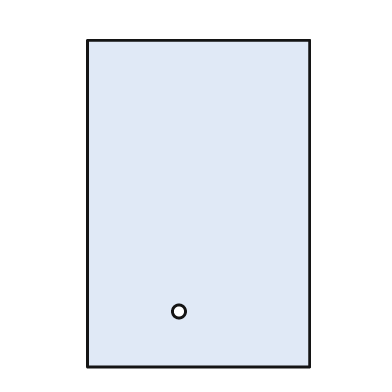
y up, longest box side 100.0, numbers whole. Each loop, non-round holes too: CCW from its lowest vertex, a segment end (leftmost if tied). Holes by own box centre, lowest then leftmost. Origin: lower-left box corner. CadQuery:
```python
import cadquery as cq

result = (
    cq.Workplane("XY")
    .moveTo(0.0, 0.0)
    .lineTo(68.0, 0.0)
    .lineTo(68.0, 100.0)
    .lineTo(0.0, 100.0)
    .close()
    .moveTo(28.0, 17.0)
    .circle(2.0)
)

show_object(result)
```